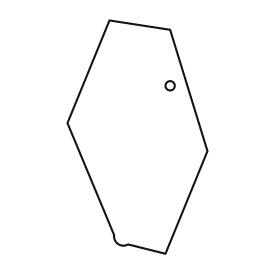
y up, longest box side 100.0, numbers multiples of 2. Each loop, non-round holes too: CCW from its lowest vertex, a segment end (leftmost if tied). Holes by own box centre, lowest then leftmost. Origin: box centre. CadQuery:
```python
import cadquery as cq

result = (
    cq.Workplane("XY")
    .moveTo(12.0, -50.0)
    .lineTo(30.0, -6.0)
    .lineTo(14.0, 46.0)
    .lineTo(-12.0, 50.0)
    .lineTo(-30.0, 6.0)
    .lineTo(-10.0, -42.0)
    .threePointArc((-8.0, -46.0), (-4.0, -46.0))
    .close()
    .moveTo(14.0, 22.0)
    .circle(2.0)
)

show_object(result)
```